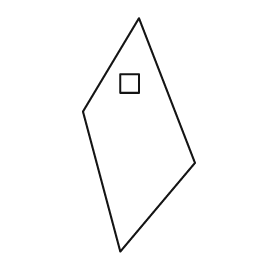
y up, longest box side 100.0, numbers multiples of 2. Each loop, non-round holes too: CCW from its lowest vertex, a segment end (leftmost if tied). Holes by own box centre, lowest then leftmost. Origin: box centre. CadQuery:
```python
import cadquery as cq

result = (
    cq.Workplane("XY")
    .moveTo(-8.0, -50.0)
    .lineTo(24.0, -12.0)
    .lineTo(0.0, 50.0)
    .lineTo(-24.0, 10.0)
    .close()
    .moveTo(-8.0, 18.0)
    .lineTo(0.0, 18.0)
    .lineTo(0.0, 26.0)
    .lineTo(-8.0, 26.0)
    .close()
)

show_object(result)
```